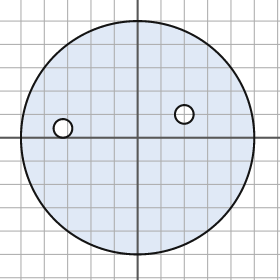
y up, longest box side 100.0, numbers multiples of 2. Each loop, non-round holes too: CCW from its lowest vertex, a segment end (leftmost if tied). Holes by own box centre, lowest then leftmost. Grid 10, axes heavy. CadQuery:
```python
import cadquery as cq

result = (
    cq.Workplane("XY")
    .moveTo(0.0, 0.0)
    .circle(50.0)
    .moveTo(-32.0, 4.0)
    .circle(4.0)
    .moveTo(20.0, 10.0)
    .circle(4.0)
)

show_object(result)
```